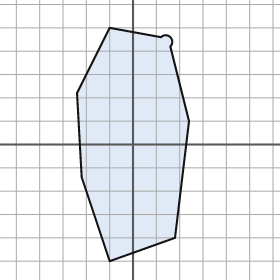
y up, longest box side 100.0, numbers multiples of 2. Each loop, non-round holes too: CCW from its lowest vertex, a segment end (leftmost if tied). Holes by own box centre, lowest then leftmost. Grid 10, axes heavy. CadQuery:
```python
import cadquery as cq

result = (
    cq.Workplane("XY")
    .moveTo(-10.0, -50.0)
    .lineTo(18.0, -40.0)
    .lineTo(24.0, 10.0)
    .lineTo(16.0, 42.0)
    .threePointArc((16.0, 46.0), (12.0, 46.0))
    .lineTo(-10.0, 50.0)
    .lineTo(-24.0, 22.0)
    .lineTo(-22.0, -14.0)
    .close()
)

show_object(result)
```